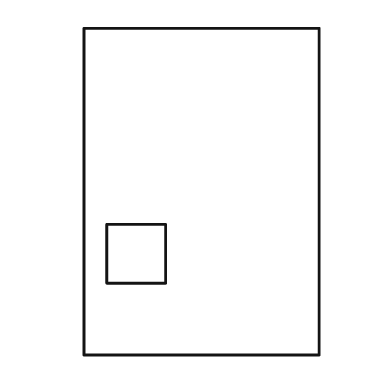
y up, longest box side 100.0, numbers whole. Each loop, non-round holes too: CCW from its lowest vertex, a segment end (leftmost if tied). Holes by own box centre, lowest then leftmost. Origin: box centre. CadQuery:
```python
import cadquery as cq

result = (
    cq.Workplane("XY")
    .moveTo(-36.0, -50.0)
    .lineTo(36.0, -50.0)
    .lineTo(36.0, 50.0)
    .lineTo(-36.0, 50.0)
    .close()
    .moveTo(-29.0, -28.0)
    .lineTo(-11.0, -28.0)
    .lineTo(-11.0, -10.0)
    .lineTo(-29.0, -10.0)
    .close()
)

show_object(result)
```